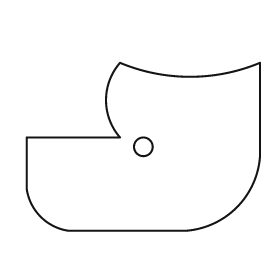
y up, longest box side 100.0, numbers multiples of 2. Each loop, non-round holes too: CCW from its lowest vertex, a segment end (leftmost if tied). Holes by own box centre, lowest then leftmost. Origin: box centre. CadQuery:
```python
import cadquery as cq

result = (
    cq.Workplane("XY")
    .moveTo(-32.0, -36.0)
    .lineTo(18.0, -36.0)
    .threePointArc((40.0, -26.0), (50.0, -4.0))
    .lineTo(50.0, 36.0)
    .threePointArc((20.0, 30.0), (-10.0, 36.0))
    .threePointArc((-16.0, 20.0), (-10.0, 4.0))
    .lineTo(-50.0, 4.0)
    .lineTo(-50.0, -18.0)
    .threePointArc((-44.0, -30.0), (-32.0, -36.0))
    .close()
    .moveTo(0.0, 0.0)
    .circle(4.0)
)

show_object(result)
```